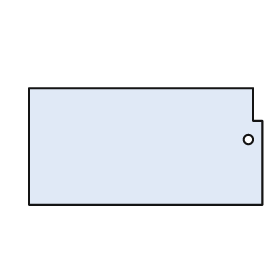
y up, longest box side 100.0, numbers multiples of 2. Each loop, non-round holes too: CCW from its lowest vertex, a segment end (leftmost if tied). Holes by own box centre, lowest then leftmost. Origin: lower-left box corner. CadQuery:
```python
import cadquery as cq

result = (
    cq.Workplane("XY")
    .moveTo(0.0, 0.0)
    .lineTo(100.0, 0.0)
    .lineTo(100.0, 36.0)
    .lineTo(96.0, 36.0)
    .lineTo(96.0, 50.0)
    .lineTo(0.0, 50.0)
    .close()
    .moveTo(94.0, 28.0)
    .circle(2.0)
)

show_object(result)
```